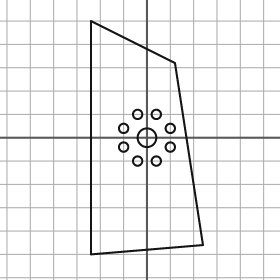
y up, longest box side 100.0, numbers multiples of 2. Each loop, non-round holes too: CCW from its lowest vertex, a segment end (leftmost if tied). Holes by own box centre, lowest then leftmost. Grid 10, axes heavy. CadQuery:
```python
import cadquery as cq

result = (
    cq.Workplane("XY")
    .moveTo(-24.0, -50.0)
    .lineTo(24.0, -46.0)
    .lineTo(12.0, 32.0)
    .lineTo(-24.0, 50.0)
    .close()
    .moveTo(-4.0, -10.0)
    .circle(2.0)
    .moveTo(4.0, -10.0)
    .circle(2.0)
    .moveTo(-10.0, -4.0)
    .circle(2.0)
    .moveTo(10.0, -4.0)
    .circle(2.0)
    .moveTo(0.0, 0.0)
    .circle(4.0)
    .moveTo(-10.0, 4.0)
    .circle(2.0)
    .moveTo(10.0, 4.0)
    .circle(2.0)
    .moveTo(-4.0, 10.0)
    .circle(2.0)
    .moveTo(4.0, 10.0)
    .circle(2.0)
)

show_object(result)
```